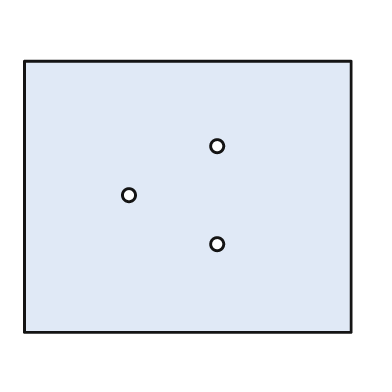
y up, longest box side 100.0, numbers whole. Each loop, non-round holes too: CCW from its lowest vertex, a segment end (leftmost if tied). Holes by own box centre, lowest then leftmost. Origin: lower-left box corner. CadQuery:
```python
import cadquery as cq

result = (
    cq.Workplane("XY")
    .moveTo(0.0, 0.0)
    .lineTo(100.0, 0.0)
    .lineTo(100.0, 83.0)
    .lineTo(0.0, 83.0)
    .close()
    .moveTo(59.0, 27.0)
    .circle(2.0)
    .moveTo(32.0, 42.0)
    .circle(2.0)
    .moveTo(59.0, 57.0)
    .circle(2.0)
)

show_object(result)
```